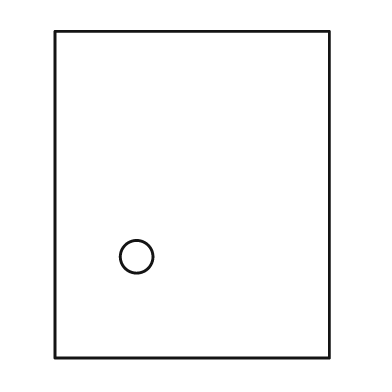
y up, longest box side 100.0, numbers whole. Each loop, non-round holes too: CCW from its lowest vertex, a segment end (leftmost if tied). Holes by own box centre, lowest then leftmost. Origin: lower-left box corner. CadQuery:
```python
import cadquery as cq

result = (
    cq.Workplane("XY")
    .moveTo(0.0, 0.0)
    .lineTo(84.0, 0.0)
    .lineTo(84.0, 100.0)
    .lineTo(0.0, 100.0)
    .close()
    .moveTo(25.0, 31.0)
    .circle(5.0)
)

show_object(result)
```